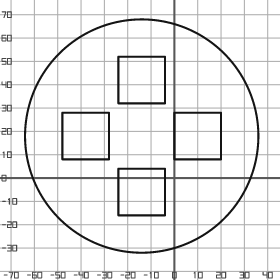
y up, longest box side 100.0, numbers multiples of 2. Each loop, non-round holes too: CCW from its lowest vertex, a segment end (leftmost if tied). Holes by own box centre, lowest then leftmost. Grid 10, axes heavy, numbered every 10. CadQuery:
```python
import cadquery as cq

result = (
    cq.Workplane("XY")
    .moveTo(-14.0, 18.0)
    .circle(50.0)
    .moveTo(-24.0, -16.0)
    .lineTo(-4.0, -16.0)
    .lineTo(-4.0, 4.0)
    .lineTo(-24.0, 4.0)
    .close()
    .moveTo(-48.0, 8.0)
    .lineTo(-28.0, 8.0)
    .lineTo(-28.0, 28.0)
    .lineTo(-48.0, 28.0)
    .close()
    .moveTo(0.0, 8.0)
    .lineTo(20.0, 8.0)
    .lineTo(20.0, 28.0)
    .lineTo(0.0, 28.0)
    .close()
    .moveTo(-24.0, 32.0)
    .lineTo(-4.0, 32.0)
    .lineTo(-4.0, 52.0)
    .lineTo(-24.0, 52.0)
    .close()
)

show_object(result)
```